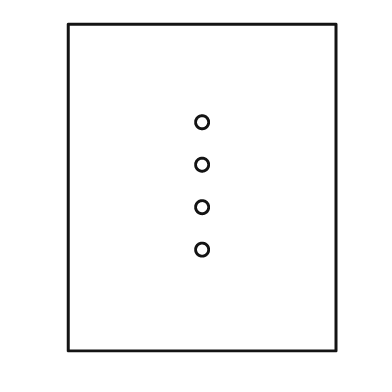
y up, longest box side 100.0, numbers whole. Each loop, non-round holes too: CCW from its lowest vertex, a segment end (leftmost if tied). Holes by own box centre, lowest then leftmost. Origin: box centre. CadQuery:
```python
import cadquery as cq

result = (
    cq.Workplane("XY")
    .moveTo(-41.0, -50.0)
    .lineTo(41.0, -50.0)
    .lineTo(41.0, 50.0)
    .lineTo(-41.0, 50.0)
    .close()
    .moveTo(0.0, -19.0)
    .circle(2.0)
    .moveTo(0.0, -6.0)
    .circle(2.0)
    .moveTo(0.0, 7.0)
    .circle(2.0)
    .moveTo(0.0, 20.0)
    .circle(2.0)
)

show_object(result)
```